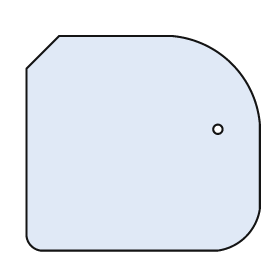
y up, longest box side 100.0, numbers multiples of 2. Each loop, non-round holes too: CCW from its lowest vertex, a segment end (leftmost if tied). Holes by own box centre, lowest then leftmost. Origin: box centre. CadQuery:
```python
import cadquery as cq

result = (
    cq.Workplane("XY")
    .moveTo(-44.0, -46.0)
    .lineTo(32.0, -46.0)
    .threePointArc((44.0, -40.0), (50.0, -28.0))
    .lineTo(50.0, 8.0)
    .threePointArc((38.0, 34.0), (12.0, 46.0))
    .lineTo(-36.0, 46.0)
    .lineTo(-50.0, 32.0)
    .lineTo(-50.0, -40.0)
    .threePointArc((-48.0, -44.0), (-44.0, -46.0))
    .close()
    .moveTo(32.0, 6.0)
    .circle(2.0)
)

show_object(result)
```